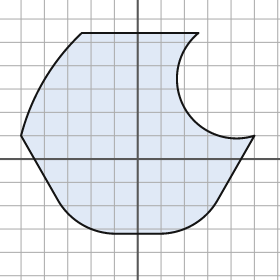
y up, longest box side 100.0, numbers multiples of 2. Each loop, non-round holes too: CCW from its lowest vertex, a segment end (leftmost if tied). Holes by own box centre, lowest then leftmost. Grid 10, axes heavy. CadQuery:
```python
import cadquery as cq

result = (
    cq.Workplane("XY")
    .moveTo(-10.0, -32.0)
    .lineTo(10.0, -32.0)
    .threePointArc((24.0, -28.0), (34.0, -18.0))
    .lineTo(50.0, 10.0)
    .threePointArc((20.0, 22.0), (26.0, 54.0))
    .lineTo(-24.0, 54.0)
    .threePointArc((-40.0, 34.0), (-50.0, 10.0))
    .lineTo(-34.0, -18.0)
    .threePointArc((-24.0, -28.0), (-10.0, -32.0))
    .close()
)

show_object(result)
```